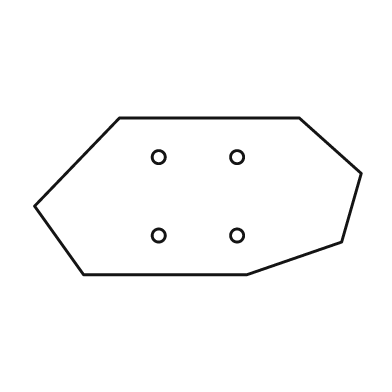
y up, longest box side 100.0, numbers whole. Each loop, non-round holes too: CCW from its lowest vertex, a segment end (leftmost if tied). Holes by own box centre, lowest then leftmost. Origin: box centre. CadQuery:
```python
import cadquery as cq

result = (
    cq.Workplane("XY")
    .moveTo(-35.0, -24.0)
    .lineTo(15.0, -24.0)
    .lineTo(44.0, -14.0)
    .lineTo(50.0, 7.0)
    .lineTo(31.0, 24.0)
    .lineTo(-24.0, 24.0)
    .lineTo(-50.0, -3.0)
    .close()
    .moveTo(-12.0, -12.0)
    .circle(2.0)
    .moveTo(12.0, -12.0)
    .circle(2.0)
    .moveTo(-12.0, 12.0)
    .circle(2.0)
    .moveTo(12.0, 12.0)
    .circle(2.0)
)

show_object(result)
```